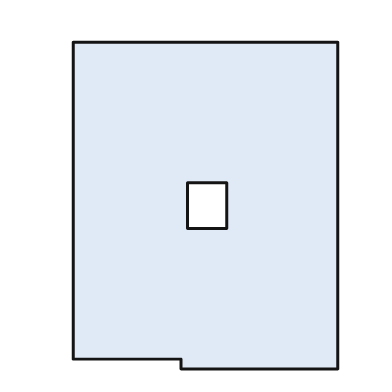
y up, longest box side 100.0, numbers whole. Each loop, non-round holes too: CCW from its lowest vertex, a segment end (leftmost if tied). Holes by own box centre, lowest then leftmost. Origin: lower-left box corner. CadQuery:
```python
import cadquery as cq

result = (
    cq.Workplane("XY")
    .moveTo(33.0, 0.0)
    .lineTo(81.0, 0.0)
    .lineTo(81.0, 100.0)
    .lineTo(0.0, 100.0)
    .lineTo(0.0, 3.0)
    .lineTo(33.0, 3.0)
    .close()
    .moveTo(35.0, 43.0)
    .lineTo(47.0, 43.0)
    .lineTo(47.0, 57.0)
    .lineTo(35.0, 57.0)
    .close()
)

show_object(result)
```